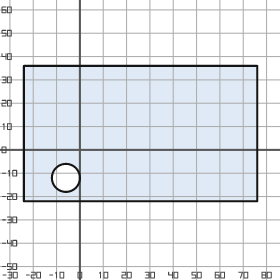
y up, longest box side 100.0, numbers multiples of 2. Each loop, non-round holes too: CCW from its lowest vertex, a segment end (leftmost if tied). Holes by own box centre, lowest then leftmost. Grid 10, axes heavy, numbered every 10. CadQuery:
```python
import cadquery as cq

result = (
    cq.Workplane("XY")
    .moveTo(-24.0, -22.0)
    .lineTo(76.0, -22.0)
    .lineTo(76.0, 36.0)
    .lineTo(-24.0, 36.0)
    .close()
    .moveTo(-6.0, -12.0)
    .circle(6.0)
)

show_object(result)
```